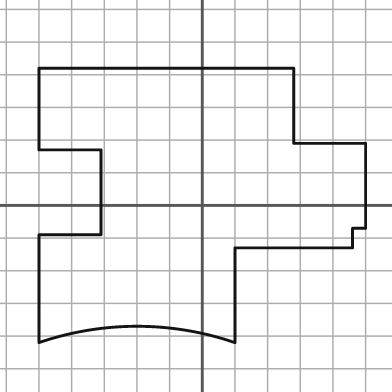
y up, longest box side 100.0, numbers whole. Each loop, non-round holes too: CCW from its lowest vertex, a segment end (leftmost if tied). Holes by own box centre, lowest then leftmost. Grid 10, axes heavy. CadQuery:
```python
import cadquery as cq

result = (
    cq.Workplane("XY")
    .moveTo(-50.0, -42.0)
    .threePointArc((-20.0, -37.0), (10.0, -42.0))
    .lineTo(10.0, -13.0)
    .lineTo(46.0, -13.0)
    .lineTo(46.0, -7.0)
    .lineTo(50.0, -7.0)
    .lineTo(50.0, 19.0)
    .lineTo(28.0, 19.0)
    .lineTo(28.0, 42.0)
    .lineTo(-50.0, 42.0)
    .lineTo(-50.0, 17.0)
    .lineTo(-31.0, 17.0)
    .lineTo(-31.0, -9.0)
    .lineTo(-50.0, -9.0)
    .close()
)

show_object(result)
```